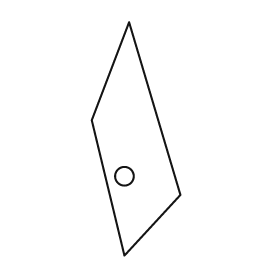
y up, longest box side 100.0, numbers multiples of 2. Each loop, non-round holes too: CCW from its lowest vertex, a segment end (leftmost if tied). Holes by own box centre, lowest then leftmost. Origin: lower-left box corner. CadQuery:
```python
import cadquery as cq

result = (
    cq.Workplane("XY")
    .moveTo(14.0, 0.0)
    .lineTo(38.0, 26.0)
    .lineTo(16.0, 100.0)
    .lineTo(0.0, 58.0)
    .close()
    .moveTo(14.0, 34.0)
    .circle(4.0)
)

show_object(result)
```